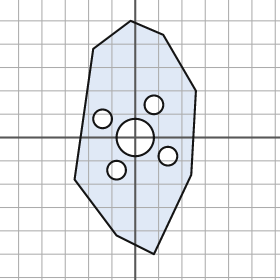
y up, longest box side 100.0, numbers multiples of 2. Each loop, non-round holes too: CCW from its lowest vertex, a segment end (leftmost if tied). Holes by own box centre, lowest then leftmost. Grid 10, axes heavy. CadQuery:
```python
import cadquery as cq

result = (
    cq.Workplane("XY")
    .moveTo(8.0, -50.0)
    .lineTo(24.0, -16.0)
    .lineTo(26.0, 20.0)
    .lineTo(12.0, 44.0)
    .lineTo(-2.0, 50.0)
    .lineTo(-18.0, 38.0)
    .lineTo(-26.0, -18.0)
    .lineTo(-8.0, -42.0)
    .close()
    .moveTo(-8.0, -14.0)
    .circle(4.0)
    .moveTo(14.0, -8.0)
    .circle(4.0)
    .moveTo(0.0, 0.0)
    .circle(8.0)
    .moveTo(-14.0, 8.0)
    .circle(4.0)
    .moveTo(8.0, 14.0)
    .circle(4.0)
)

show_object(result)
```